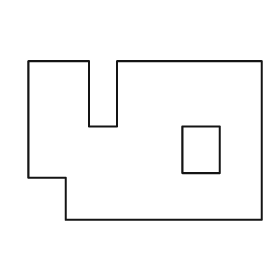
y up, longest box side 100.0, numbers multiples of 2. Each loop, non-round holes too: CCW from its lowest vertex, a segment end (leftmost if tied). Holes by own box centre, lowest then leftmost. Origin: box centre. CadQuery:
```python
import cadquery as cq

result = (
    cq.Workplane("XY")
    .moveTo(-34.0, -34.0)
    .lineTo(50.0, -34.0)
    .lineTo(50.0, 34.0)
    .lineTo(-12.0, 34.0)
    .lineTo(-12.0, 6.0)
    .lineTo(-24.0, 6.0)
    .lineTo(-24.0, 34.0)
    .lineTo(-50.0, 34.0)
    .lineTo(-50.0, -16.0)
    .lineTo(-34.0, -16.0)
    .close()
    .moveTo(16.0, -14.0)
    .lineTo(32.0, -14.0)
    .lineTo(32.0, 6.0)
    .lineTo(16.0, 6.0)
    .close()
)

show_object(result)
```